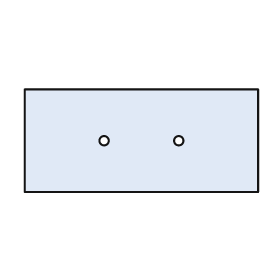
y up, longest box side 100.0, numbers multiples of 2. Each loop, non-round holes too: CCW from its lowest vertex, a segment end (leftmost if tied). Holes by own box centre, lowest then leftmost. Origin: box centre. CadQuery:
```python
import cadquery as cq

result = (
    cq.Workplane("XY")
    .moveTo(-50.0, -22.0)
    .lineTo(50.0, -22.0)
    .lineTo(50.0, 22.0)
    .lineTo(-50.0, 22.0)
    .close()
    .moveTo(-16.0, 0.0)
    .circle(2.0)
    .moveTo(16.0, 0.0)
    .circle(2.0)
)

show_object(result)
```